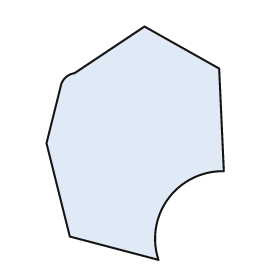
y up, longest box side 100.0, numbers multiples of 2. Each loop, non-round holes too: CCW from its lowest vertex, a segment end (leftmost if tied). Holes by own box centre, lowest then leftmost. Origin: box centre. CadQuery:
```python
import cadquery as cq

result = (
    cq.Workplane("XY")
    .moveTo(10.0, -50.0)
    .threePointArc((14.0, -24.0), (38.0, -12.0))
    .lineTo(36.0, 32.0)
    .lineTo(4.0, 50.0)
    .lineTo(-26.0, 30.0)
    .threePointArc((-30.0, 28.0), (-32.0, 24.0))
    .lineTo(-38.0, 0.0)
    .lineTo(-28.0, -40.0)
    .close()
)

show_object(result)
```